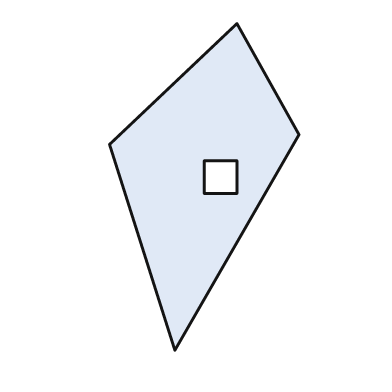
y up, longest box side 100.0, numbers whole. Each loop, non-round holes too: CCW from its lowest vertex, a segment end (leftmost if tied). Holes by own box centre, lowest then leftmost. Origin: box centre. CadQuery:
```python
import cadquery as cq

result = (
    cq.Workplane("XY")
    .moveTo(-9.0, -50.0)
    .lineTo(29.0, 16.0)
    .lineTo(10.0, 50.0)
    .lineTo(-29.0, 13.0)
    .close()
    .moveTo(0.0, -2.0)
    .lineTo(10.0, -2.0)
    .lineTo(10.0, 8.0)
    .lineTo(0.0, 8.0)
    .close()
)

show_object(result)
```